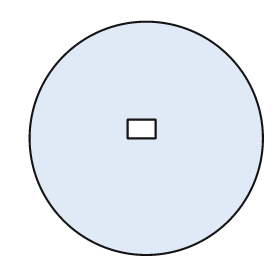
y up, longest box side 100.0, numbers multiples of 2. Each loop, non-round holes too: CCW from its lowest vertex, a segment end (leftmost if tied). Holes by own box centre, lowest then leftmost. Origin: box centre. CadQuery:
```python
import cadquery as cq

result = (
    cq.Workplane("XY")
    .moveTo(0.0, 0.0)
    .circle(50.0)
    .moveTo(-8.0, 0.0)
    .lineTo(4.0, 0.0)
    .lineTo(4.0, 8.0)
    .lineTo(-8.0, 8.0)
    .close()
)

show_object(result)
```